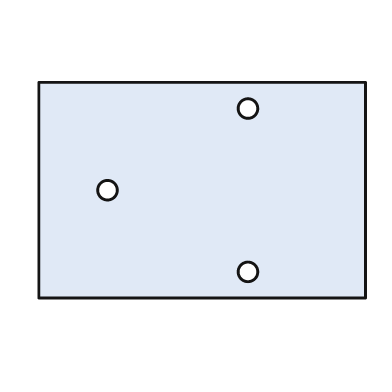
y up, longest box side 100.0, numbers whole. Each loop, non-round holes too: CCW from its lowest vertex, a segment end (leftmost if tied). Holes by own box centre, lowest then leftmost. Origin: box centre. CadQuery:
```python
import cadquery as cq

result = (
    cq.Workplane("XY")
    .moveTo(-50.0, -33.0)
    .lineTo(50.0, -33.0)
    .lineTo(50.0, 33.0)
    .lineTo(-50.0, 33.0)
    .close()
    .moveTo(14.0, -25.0)
    .circle(3.0)
    .moveTo(-29.0, 0.0)
    .circle(3.0)
    .moveTo(14.0, 25.0)
    .circle(3.0)
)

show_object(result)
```